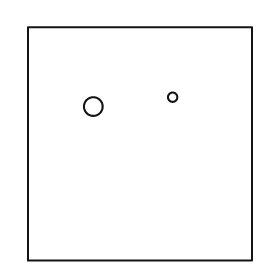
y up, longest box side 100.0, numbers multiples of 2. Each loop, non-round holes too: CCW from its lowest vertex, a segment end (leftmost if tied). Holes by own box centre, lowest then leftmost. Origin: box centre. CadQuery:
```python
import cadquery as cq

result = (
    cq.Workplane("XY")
    .moveTo(-48.0, -50.0)
    .lineTo(48.0, -50.0)
    .lineTo(48.0, 50.0)
    .lineTo(-48.0, 50.0)
    .close()
    .moveTo(-20.0, 16.0)
    .circle(4.0)
    .moveTo(14.0, 20.0)
    .circle(2.0)
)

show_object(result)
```